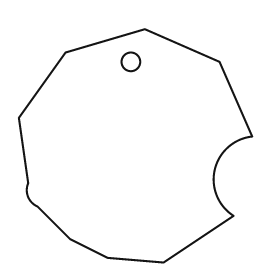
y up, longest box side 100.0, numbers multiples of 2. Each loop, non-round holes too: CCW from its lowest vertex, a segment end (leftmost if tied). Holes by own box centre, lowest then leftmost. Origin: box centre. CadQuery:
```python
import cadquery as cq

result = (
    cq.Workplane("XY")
    .moveTo(12.0, -50.0)
    .lineTo(42.0, -30.0)
    .threePointArc((34.0, -10.0), (50.0, 4.0))
    .lineTo(36.0, 36.0)
    .lineTo(4.0, 50.0)
    .lineTo(-30.0, 40.0)
    .lineTo(-50.0, 12.0)
    .lineTo(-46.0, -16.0)
    .threePointArc((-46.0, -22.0), (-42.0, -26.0))
    .lineTo(-28.0, -40.0)
    .lineTo(-12.0, -48.0)
    .close()
    .moveTo(-2.0, 36.0)
    .circle(4.0)
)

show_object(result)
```